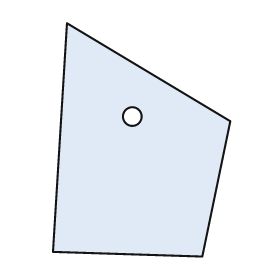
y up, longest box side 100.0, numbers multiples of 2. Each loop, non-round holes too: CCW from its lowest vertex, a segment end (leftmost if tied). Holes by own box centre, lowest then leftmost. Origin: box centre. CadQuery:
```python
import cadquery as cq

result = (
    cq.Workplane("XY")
    .moveTo(26.0, -50.0)
    .lineTo(38.0, 8.0)
    .lineTo(-32.0, 50.0)
    .lineTo(-38.0, -48.0)
    .close()
    .moveTo(-4.0, 10.0)
    .circle(4.0)
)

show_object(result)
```